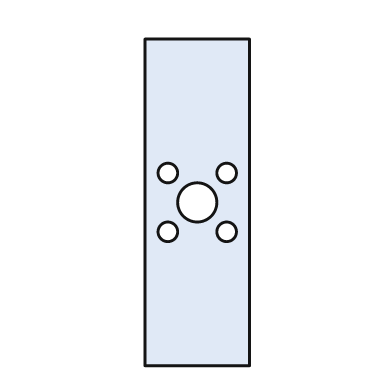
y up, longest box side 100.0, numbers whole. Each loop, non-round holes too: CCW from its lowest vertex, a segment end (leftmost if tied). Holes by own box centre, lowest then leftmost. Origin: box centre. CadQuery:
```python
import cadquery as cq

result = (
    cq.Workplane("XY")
    .moveTo(-16.0, -50.0)
    .lineTo(16.0, -50.0)
    .lineTo(16.0, 50.0)
    .lineTo(-16.0, 50.0)
    .close()
    .moveTo(-9.0, -9.0)
    .circle(3.0)
    .moveTo(9.0, -9.0)
    .circle(3.0)
    .moveTo(0.0, 0.0)
    .circle(6.0)
    .moveTo(-9.0, 9.0)
    .circle(3.0)
    .moveTo(9.0, 9.0)
    .circle(3.0)
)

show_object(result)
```